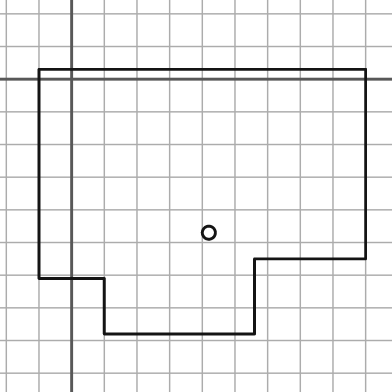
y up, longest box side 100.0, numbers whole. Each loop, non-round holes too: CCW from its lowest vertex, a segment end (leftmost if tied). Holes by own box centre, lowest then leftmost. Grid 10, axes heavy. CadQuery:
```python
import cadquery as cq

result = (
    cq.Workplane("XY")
    .moveTo(10.0, -78.0)
    .lineTo(56.0, -78.0)
    .lineTo(56.0, -55.0)
    .lineTo(90.0, -55.0)
    .lineTo(90.0, 3.0)
    .lineTo(-10.0, 3.0)
    .lineTo(-10.0, -61.0)
    .lineTo(10.0, -61.0)
    .close()
    .moveTo(42.0, -47.0)
    .circle(2.0)
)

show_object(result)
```